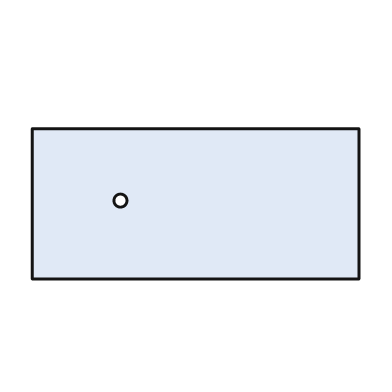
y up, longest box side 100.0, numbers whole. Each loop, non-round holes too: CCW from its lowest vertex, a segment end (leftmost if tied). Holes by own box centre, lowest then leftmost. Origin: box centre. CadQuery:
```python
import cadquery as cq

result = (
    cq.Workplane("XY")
    .moveTo(-50.0, -23.0)
    .lineTo(50.0, -23.0)
    .lineTo(50.0, 23.0)
    .lineTo(-50.0, 23.0)
    .close()
    .moveTo(-23.0, 1.0)
    .circle(2.0)
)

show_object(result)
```